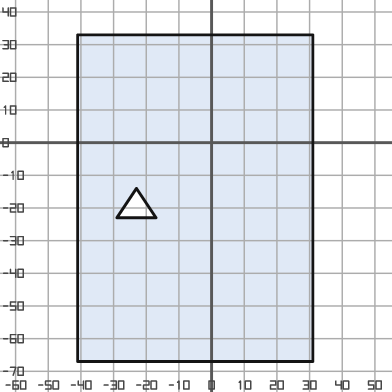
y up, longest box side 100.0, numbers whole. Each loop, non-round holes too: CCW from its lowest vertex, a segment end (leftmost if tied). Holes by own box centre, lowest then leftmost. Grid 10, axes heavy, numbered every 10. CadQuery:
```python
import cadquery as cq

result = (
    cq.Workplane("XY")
    .moveTo(-41.0, -67.0)
    .lineTo(31.0, -67.0)
    .lineTo(31.0, 33.0)
    .lineTo(-41.0, 33.0)
    .close()
    .moveTo(-29.0, -23.0)
    .lineTo(-17.0, -23.0)
    .lineTo(-23.0, -14.0)
    .close()
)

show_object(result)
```